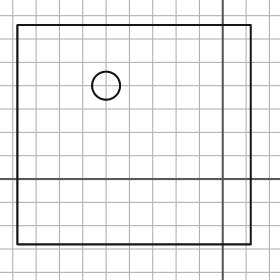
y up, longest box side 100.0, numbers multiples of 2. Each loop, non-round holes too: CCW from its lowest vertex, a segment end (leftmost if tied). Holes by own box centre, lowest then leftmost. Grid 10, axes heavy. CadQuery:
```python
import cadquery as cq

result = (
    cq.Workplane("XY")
    .moveTo(-88.0, -28.0)
    .lineTo(12.0, -28.0)
    .lineTo(12.0, 66.0)
    .lineTo(-88.0, 66.0)
    .close()
    .moveTo(-50.0, 40.0)
    .circle(6.0)
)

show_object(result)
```